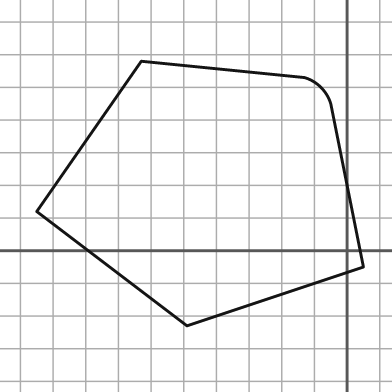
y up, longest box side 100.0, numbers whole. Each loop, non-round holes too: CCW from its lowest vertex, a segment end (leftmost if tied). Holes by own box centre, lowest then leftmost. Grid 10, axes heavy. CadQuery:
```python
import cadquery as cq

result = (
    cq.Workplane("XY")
    .moveTo(-49.0, -23.0)
    .lineTo(5.0, -5.0)
    .lineTo(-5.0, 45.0)
    .threePointArc((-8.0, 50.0), (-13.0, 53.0))
    .lineTo(-63.0, 58.0)
    .lineTo(-95.0, 12.0)
    .close()
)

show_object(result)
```